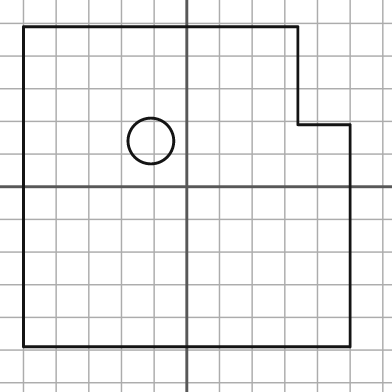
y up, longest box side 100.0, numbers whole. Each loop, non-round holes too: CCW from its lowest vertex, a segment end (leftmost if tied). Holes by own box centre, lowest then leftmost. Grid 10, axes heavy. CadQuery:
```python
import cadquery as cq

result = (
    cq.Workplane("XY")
    .moveTo(-50.0, -49.0)
    .lineTo(50.0, -49.0)
    .lineTo(50.0, 19.0)
    .lineTo(34.0, 19.0)
    .lineTo(34.0, 49.0)
    .lineTo(-50.0, 49.0)
    .close()
    .moveTo(-11.0, 14.0)
    .circle(7.0)
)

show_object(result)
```